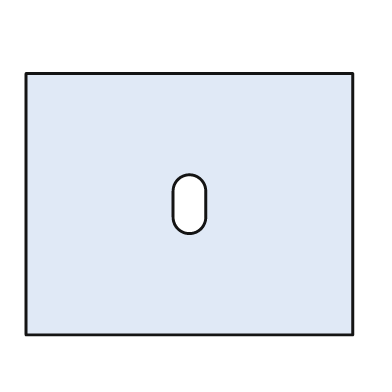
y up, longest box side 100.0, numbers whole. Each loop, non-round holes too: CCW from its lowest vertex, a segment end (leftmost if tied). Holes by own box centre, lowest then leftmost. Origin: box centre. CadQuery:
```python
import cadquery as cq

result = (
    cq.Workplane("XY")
    .moveTo(-50.0, -40.0)
    .lineTo(50.0, -40.0)
    .lineTo(50.0, 40.0)
    .lineTo(-50.0, 40.0)
    .close()
    .moveTo(-5.0, -4.0)
    .threePointArc((0.0, -9.0), (5.0, -4.0))
    .lineTo(5.0, 4.0)
    .threePointArc((0.0, 9.0), (-5.0, 4.0))
    .close()
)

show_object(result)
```